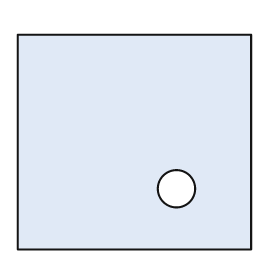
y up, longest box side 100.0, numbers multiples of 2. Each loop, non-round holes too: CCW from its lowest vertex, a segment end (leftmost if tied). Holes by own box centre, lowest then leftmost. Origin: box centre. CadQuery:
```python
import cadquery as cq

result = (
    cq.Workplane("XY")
    .moveTo(-50.0, -46.0)
    .lineTo(50.0, -46.0)
    .lineTo(50.0, 46.0)
    .lineTo(-50.0, 46.0)
    .close()
    .moveTo(18.0, -20.0)
    .circle(8.0)
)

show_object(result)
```